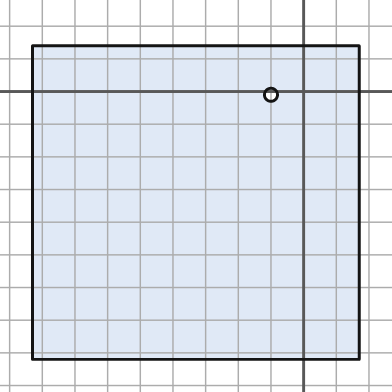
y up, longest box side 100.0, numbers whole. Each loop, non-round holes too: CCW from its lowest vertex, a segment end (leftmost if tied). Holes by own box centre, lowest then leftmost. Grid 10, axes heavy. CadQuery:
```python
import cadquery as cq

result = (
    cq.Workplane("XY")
    .moveTo(-83.0, -82.0)
    .lineTo(17.0, -82.0)
    .lineTo(17.0, 14.0)
    .lineTo(-83.0, 14.0)
    .close()
    .moveTo(-10.0, -1.0)
    .circle(2.0)
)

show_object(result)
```